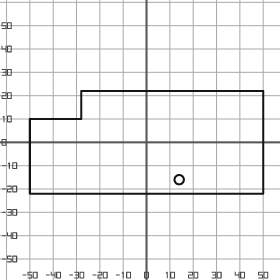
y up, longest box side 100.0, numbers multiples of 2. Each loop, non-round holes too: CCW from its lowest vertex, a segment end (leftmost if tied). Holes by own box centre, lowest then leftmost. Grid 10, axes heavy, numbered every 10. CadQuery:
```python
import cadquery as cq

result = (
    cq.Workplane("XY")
    .moveTo(-50.0, -22.0)
    .lineTo(50.0, -22.0)
    .lineTo(50.0, 22.0)
    .lineTo(-28.0, 22.0)
    .lineTo(-28.0, 10.0)
    .lineTo(-50.0, 10.0)
    .close()
    .moveTo(14.0, -16.0)
    .circle(2.0)
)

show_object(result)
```